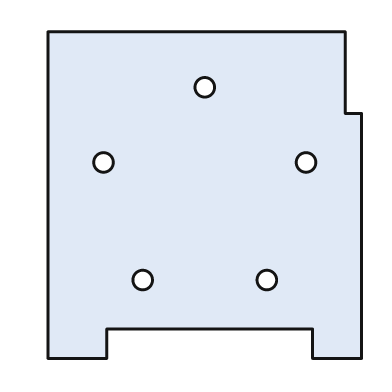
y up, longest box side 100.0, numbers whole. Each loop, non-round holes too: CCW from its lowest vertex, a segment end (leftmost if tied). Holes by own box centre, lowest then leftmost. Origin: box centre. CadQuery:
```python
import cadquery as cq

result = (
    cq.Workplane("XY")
    .moveTo(-48.0, -50.0)
    .lineTo(-30.0, -50.0)
    .lineTo(-30.0, -41.0)
    .lineTo(33.0, -41.0)
    .lineTo(33.0, -50.0)
    .lineTo(48.0, -50.0)
    .lineTo(48.0, 25.0)
    .lineTo(43.0, 25.0)
    .lineTo(43.0, 50.0)
    .lineTo(-48.0, 50.0)
    .close()
    .moveTo(-19.0, -26.0)
    .circle(3.0)
    .moveTo(19.0, -26.0)
    .circle(3.0)
    .moveTo(-31.0, 10.0)
    .circle(3.0)
    .moveTo(31.0, 10.0)
    .circle(3.0)
    .moveTo(0.0, 33.0)
    .circle(3.0)
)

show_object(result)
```